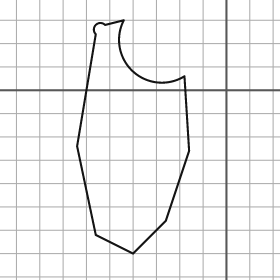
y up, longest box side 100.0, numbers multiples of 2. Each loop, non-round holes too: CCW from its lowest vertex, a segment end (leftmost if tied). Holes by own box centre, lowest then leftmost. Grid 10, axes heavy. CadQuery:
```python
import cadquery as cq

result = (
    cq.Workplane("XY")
    .moveTo(-40.0, -70.0)
    .lineTo(-26.0, -56.0)
    .lineTo(-16.0, -26.0)
    .lineTo(-18.0, 6.0)
    .threePointArc((-40.0, 8.0), (-44.0, 30.0))
    .lineTo(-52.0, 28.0)
    .threePointArc((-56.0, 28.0), (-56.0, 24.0))
    .lineTo(-64.0, -24.0)
    .lineTo(-56.0, -62.0)
    .close()
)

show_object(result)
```